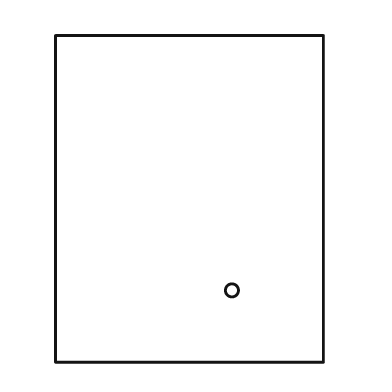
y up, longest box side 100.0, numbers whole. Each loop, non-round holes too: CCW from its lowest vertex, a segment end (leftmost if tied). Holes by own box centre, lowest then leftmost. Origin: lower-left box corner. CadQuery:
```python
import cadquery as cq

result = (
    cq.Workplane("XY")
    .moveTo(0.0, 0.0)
    .lineTo(82.0, 0.0)
    .lineTo(82.0, 100.0)
    .lineTo(0.0, 100.0)
    .close()
    .moveTo(54.0, 22.0)
    .circle(2.0)
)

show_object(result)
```